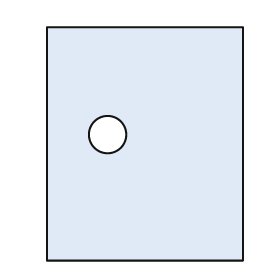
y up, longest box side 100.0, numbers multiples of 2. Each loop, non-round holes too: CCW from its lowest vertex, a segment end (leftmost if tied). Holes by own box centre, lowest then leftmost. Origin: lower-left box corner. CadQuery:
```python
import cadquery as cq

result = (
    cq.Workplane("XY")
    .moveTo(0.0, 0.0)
    .lineTo(84.0, 0.0)
    .lineTo(84.0, 100.0)
    .lineTo(0.0, 100.0)
    .close()
    .moveTo(26.0, 54.0)
    .circle(8.0)
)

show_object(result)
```